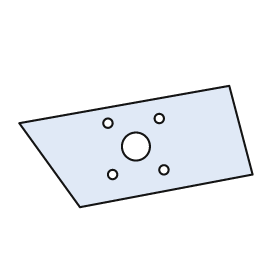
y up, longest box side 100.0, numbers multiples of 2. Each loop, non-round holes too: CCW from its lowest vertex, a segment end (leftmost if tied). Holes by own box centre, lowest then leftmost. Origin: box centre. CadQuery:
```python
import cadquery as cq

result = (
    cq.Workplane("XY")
    .moveTo(-24.0, -26.0)
    .lineTo(50.0, -12.0)
    .lineTo(40.0, 26.0)
    .lineTo(-50.0, 10.0)
    .close()
    .moveTo(-10.0, -12.0)
    .circle(2.0)
    .moveTo(12.0, -10.0)
    .circle(2.0)
    .moveTo(0.0, 0.0)
    .circle(6.0)
    .moveTo(-12.0, 10.0)
    .circle(2.0)
    .moveTo(10.0, 12.0)
    .circle(2.0)
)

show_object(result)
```